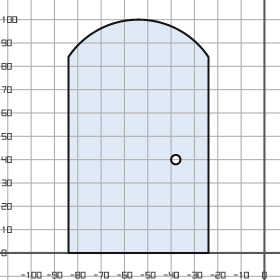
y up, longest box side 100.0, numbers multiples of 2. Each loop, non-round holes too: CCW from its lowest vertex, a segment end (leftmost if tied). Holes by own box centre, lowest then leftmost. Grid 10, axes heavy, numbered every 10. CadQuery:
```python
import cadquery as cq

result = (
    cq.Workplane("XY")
    .moveTo(-84.0, 0.0)
    .lineTo(-24.0, 0.0)
    .lineTo(-24.0, 84.0)
    .threePointArc((-54.0, 100.0), (-84.0, 84.0))
    .close()
    .moveTo(-38.0, 40.0)
    .circle(2.0)
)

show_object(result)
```